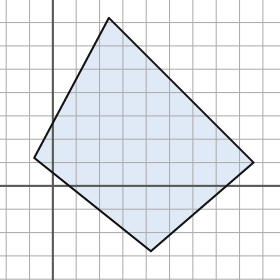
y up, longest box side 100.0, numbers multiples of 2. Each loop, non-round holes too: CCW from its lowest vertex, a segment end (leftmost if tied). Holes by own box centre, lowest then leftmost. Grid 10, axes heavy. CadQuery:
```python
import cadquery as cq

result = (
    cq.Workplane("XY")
    .moveTo(42.0, -28.0)
    .lineTo(86.0, 10.0)
    .lineTo(24.0, 72.0)
    .lineTo(-8.0, 12.0)
    .close()
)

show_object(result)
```